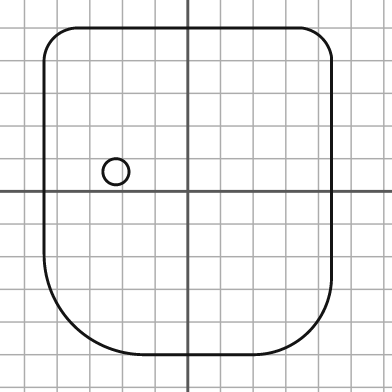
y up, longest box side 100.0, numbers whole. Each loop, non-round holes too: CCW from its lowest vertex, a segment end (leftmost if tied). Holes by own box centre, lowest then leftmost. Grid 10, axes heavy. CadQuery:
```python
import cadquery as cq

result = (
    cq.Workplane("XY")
    .moveTo(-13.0, -50.0)
    .lineTo(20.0, -50.0)
    .threePointArc((37.0, -43.0), (44.0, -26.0))
    .lineTo(44.0, 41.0)
    .threePointArc((41.0, 47.0), (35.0, 50.0))
    .lineTo(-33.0, 50.0)
    .threePointArc((-41.0, 47.0), (-44.0, 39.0))
    .lineTo(-44.0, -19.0)
    .threePointArc((-35.0, -41.0), (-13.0, -50.0))
    .close()
    .moveTo(-22.0, 6.0)
    .circle(4.0)
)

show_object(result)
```